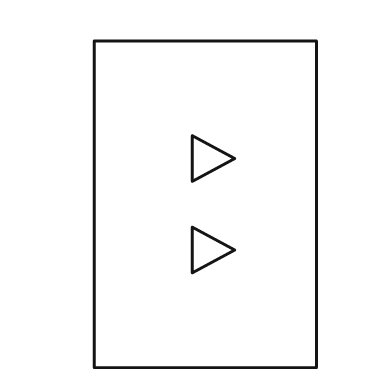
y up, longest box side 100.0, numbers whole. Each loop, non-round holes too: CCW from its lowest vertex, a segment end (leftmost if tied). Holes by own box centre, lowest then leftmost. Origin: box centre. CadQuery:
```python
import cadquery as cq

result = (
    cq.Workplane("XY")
    .moveTo(-34.0, -50.0)
    .lineTo(34.0, -50.0)
    .lineTo(34.0, 50.0)
    .lineTo(-34.0, 50.0)
    .close()
    .moveTo(-4.0, -21.0)
    .lineTo(9.0, -14.0)
    .lineTo(-4.0, -7.0)
    .close()
    .moveTo(-4.0, 7.0)
    .lineTo(9.0, 14.0)
    .lineTo(-4.0, 21.0)
    .close()
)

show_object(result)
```